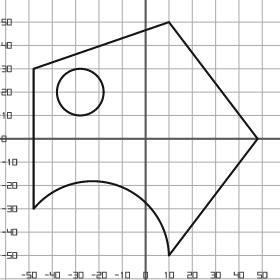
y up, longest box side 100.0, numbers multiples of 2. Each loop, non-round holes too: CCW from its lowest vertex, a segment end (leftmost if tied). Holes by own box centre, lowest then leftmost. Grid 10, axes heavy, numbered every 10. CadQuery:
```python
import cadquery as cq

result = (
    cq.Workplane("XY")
    .moveTo(10.0, -50.0)
    .lineTo(48.0, 0.0)
    .lineTo(10.0, 50.0)
    .lineTo(-48.0, 30.0)
    .lineTo(-48.0, -30.0)
    .threePointArc((-12.0, -20.0), (10.0, -50.0))
    .close()
    .moveTo(-28.0, 20.0)
    .circle(10.0)
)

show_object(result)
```